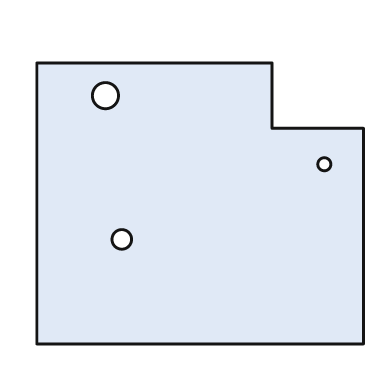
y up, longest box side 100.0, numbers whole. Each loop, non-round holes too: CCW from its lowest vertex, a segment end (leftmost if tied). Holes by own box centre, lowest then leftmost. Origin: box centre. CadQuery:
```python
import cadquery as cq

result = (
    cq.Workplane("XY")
    .moveTo(-50.0, -43.0)
    .lineTo(50.0, -43.0)
    .lineTo(50.0, 23.0)
    .lineTo(22.0, 23.0)
    .lineTo(22.0, 43.0)
    .lineTo(-50.0, 43.0)
    .close()
    .moveTo(-24.0, -11.0)
    .circle(3.0)
    .moveTo(38.0, 12.0)
    .circle(2.0)
    .moveTo(-29.0, 33.0)
    .circle(4.0)
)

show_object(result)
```